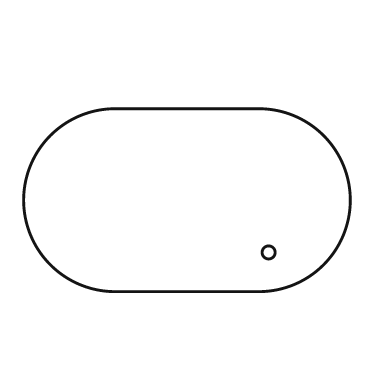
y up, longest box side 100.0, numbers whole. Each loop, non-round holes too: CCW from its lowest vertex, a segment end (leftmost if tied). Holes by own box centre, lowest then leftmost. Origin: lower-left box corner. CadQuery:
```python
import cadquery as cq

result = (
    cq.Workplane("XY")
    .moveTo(28.0, 0.0)
    .lineTo(72.0, 0.0)
    .threePointArc((100.0, 28.0), (72.0, 56.0))
    .lineTo(28.0, 56.0)
    .threePointArc((0.0, 28.0), (28.0, 0.0))
    .close()
    .moveTo(75.0, 12.0)
    .circle(2.0)
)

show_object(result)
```